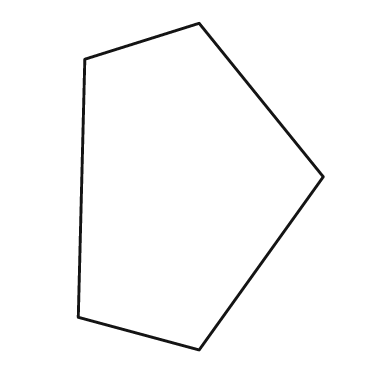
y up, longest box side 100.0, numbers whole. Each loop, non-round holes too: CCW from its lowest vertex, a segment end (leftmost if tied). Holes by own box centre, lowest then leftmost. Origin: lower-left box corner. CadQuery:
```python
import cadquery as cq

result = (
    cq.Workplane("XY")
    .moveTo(37.0, 0.0)
    .lineTo(75.0, 53.0)
    .lineTo(37.0, 100.0)
    .lineTo(2.0, 89.0)
    .lineTo(0.0, 10.0)
    .close()
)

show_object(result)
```